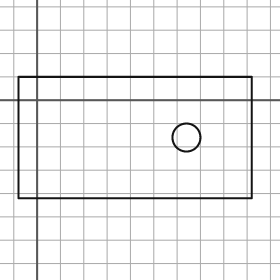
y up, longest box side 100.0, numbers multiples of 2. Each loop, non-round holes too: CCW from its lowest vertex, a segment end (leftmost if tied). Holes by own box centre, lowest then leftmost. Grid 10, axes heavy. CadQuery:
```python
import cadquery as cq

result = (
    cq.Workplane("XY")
    .moveTo(-8.0, -42.0)
    .lineTo(92.0, -42.0)
    .lineTo(92.0, 10.0)
    .lineTo(-8.0, 10.0)
    .close()
    .moveTo(64.0, -16.0)
    .circle(6.0)
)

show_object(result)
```